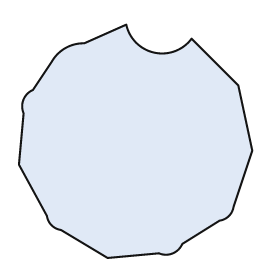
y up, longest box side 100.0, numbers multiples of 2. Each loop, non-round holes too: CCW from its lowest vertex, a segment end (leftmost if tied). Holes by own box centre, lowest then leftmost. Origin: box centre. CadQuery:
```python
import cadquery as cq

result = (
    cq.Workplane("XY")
    .moveTo(-12.0, -50.0)
    .lineTo(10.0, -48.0)
    .threePointArc((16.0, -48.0), (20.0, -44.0))
    .lineTo(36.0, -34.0)
    .threePointArc((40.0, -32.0), (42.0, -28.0))
    .lineTo(50.0, -4.0)
    .lineTo(44.0, 24.0)
    .lineTo(24.0, 44.0)
    .threePointArc((8.0, 38.0), (-4.0, 50.0))
    .lineTo(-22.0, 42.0)
    .threePointArc((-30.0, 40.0), (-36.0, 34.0))
    .lineTo(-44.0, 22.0)
    .threePointArc((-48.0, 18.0), (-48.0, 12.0))
    .lineTo(-50.0, -10.0)
    .lineTo(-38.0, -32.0)
    .threePointArc((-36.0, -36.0), (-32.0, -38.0))
    .close()
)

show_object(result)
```